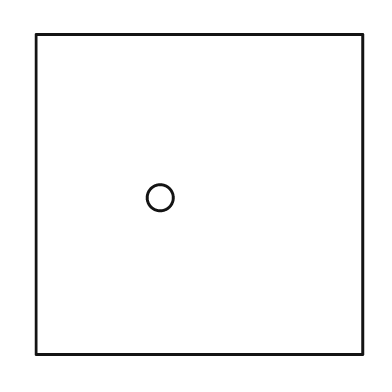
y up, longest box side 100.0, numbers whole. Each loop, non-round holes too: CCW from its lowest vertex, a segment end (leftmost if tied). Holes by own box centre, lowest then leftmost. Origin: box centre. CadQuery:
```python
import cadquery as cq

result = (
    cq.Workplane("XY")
    .moveTo(-50.0, -49.0)
    .lineTo(50.0, -49.0)
    .lineTo(50.0, 49.0)
    .lineTo(-50.0, 49.0)
    .close()
    .moveTo(-12.0, -1.0)
    .circle(4.0)
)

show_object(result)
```